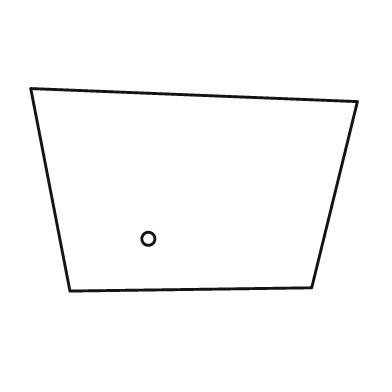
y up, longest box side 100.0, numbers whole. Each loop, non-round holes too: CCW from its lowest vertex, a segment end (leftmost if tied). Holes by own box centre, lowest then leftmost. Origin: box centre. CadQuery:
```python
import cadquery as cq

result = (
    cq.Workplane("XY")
    .moveTo(-38.0, -31.0)
    .lineTo(36.0, -30.0)
    .lineTo(50.0, 27.0)
    .lineTo(-50.0, 31.0)
    .close()
    .moveTo(-14.0, -15.0)
    .circle(2.0)
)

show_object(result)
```